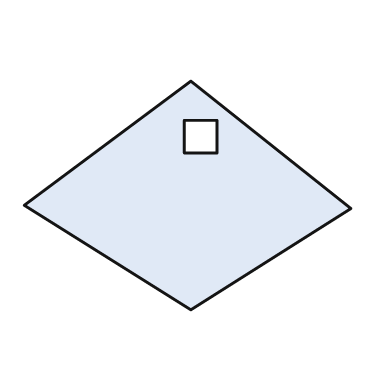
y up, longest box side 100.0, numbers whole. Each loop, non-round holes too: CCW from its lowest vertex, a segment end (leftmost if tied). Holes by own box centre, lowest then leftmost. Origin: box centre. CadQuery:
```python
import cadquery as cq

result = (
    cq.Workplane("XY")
    .moveTo(1.0, -35.0)
    .lineTo(50.0, -4.0)
    .lineTo(1.0, 35.0)
    .lineTo(-50.0, -3.0)
    .close()
    .moveTo(-1.0, 13.0)
    .lineTo(9.0, 13.0)
    .lineTo(9.0, 23.0)
    .lineTo(-1.0, 23.0)
    .close()
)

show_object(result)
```